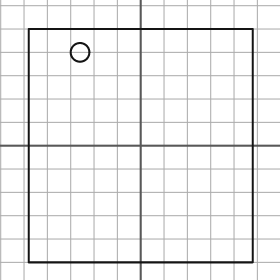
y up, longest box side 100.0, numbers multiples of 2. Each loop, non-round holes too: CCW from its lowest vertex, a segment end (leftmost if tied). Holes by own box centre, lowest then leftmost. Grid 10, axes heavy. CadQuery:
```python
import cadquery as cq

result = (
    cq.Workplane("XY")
    .moveTo(-48.0, -50.0)
    .lineTo(48.0, -50.0)
    .lineTo(48.0, 50.0)
    .lineTo(-48.0, 50.0)
    .close()
    .moveTo(-26.0, 40.0)
    .circle(4.0)
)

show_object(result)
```